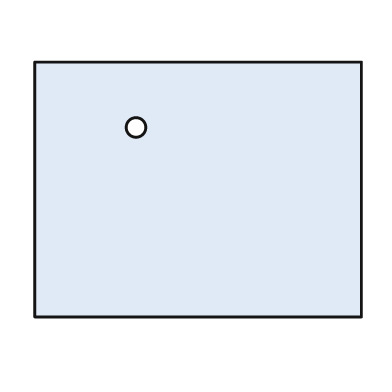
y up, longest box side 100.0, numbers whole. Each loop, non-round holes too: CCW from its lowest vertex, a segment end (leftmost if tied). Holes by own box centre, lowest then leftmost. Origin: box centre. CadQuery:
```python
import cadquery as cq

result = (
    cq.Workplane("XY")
    .moveTo(-50.0, -39.0)
    .lineTo(50.0, -39.0)
    .lineTo(50.0, 39.0)
    .lineTo(-50.0, 39.0)
    .close()
    .moveTo(-19.0, 19.0)
    .circle(3.0)
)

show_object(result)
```